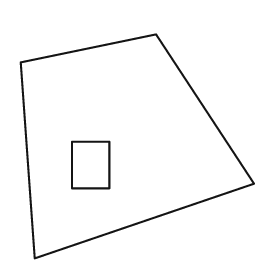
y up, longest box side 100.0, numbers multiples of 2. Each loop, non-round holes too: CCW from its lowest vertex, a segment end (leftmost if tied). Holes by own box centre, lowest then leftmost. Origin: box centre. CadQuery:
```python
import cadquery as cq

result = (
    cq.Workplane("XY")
    .moveTo(-44.0, -48.0)
    .lineTo(50.0, -16.0)
    .lineTo(8.0, 48.0)
    .lineTo(-50.0, 36.0)
    .close()
    .moveTo(-28.0, -18.0)
    .lineTo(-12.0, -18.0)
    .lineTo(-12.0, 2.0)
    .lineTo(-28.0, 2.0)
    .close()
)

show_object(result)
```